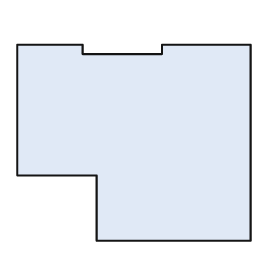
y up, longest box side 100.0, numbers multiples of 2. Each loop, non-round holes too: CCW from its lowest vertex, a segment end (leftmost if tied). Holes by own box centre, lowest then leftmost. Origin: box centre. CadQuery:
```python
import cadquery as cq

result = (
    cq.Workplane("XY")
    .moveTo(-16.0, -42.0)
    .lineTo(50.0, -42.0)
    .lineTo(50.0, 42.0)
    .lineTo(12.0, 42.0)
    .lineTo(12.0, 38.0)
    .lineTo(-22.0, 38.0)
    .lineTo(-22.0, 42.0)
    .lineTo(-50.0, 42.0)
    .lineTo(-50.0, -14.0)
    .lineTo(-16.0, -14.0)
    .close()
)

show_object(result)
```